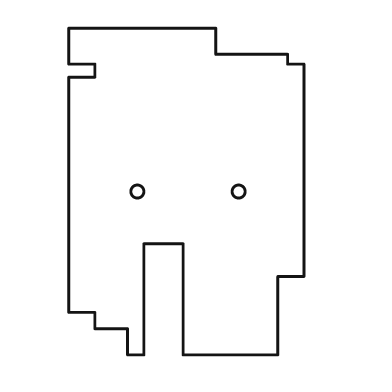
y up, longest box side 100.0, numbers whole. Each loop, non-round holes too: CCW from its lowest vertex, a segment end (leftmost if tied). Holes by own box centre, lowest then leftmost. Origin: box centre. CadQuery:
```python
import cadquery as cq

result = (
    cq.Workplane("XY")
    .moveTo(-18.0, -50.0)
    .lineTo(-13.0, -50.0)
    .lineTo(-13.0, -16.0)
    .lineTo(-1.0, -16.0)
    .lineTo(-1.0, -50.0)
    .lineTo(28.0, -50.0)
    .lineTo(28.0, -26.0)
    .lineTo(36.0, -26.0)
    .lineTo(36.0, 39.0)
    .lineTo(31.0, 39.0)
    .lineTo(31.0, 42.0)
    .lineTo(9.0, 42.0)
    .lineTo(9.0, 50.0)
    .lineTo(-36.0, 50.0)
    .lineTo(-36.0, 39.0)
    .lineTo(-28.0, 39.0)
    .lineTo(-28.0, 35.0)
    .lineTo(-36.0, 35.0)
    .lineTo(-36.0, -37.0)
    .lineTo(-28.0, -37.0)
    .lineTo(-28.0, -42.0)
    .lineTo(-18.0, -42.0)
    .close()
    .moveTo(-15.0, 0.0)
    .circle(2.0)
    .moveTo(16.0, 0.0)
    .circle(2.0)
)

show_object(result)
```